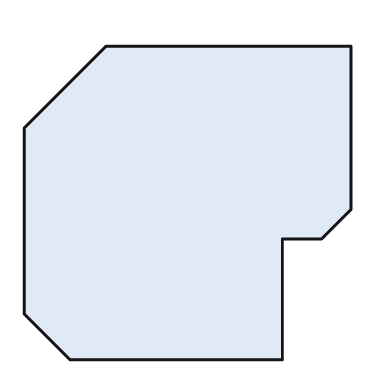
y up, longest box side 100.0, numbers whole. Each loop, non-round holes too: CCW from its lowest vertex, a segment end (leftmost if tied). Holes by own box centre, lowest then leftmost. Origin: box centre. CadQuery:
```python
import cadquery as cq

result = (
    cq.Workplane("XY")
    .moveTo(-36.0, -48.0)
    .lineTo(29.0, -48.0)
    .lineTo(29.0, -11.0)
    .lineTo(41.0, -11.0)
    .lineTo(50.0, -2.0)
    .lineTo(50.0, 48.0)
    .lineTo(-25.0, 48.0)
    .lineTo(-50.0, 23.0)
    .lineTo(-50.0, -34.0)
    .close()
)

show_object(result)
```